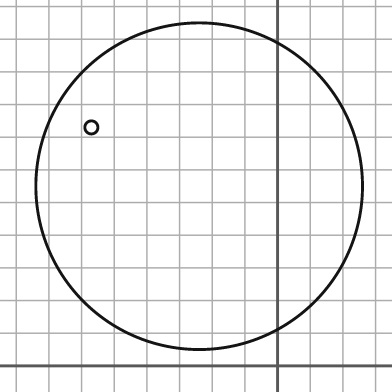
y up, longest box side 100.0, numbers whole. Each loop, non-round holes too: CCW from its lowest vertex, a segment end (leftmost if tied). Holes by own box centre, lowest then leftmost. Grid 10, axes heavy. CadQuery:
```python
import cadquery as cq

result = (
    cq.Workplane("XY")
    .moveTo(-24.0, 55.0)
    .circle(50.0)
    .moveTo(-57.0, 73.0)
    .circle(2.0)
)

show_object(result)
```